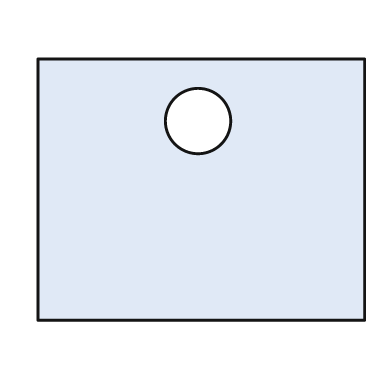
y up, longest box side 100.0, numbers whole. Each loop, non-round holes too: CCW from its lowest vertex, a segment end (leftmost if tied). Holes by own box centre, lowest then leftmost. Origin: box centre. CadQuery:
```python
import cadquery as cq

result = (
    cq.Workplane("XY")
    .moveTo(-50.0, -40.0)
    .lineTo(50.0, -40.0)
    .lineTo(50.0, 40.0)
    .lineTo(-50.0, 40.0)
    .close()
    .moveTo(-1.0, 21.0)
    .circle(10.0)
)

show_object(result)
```